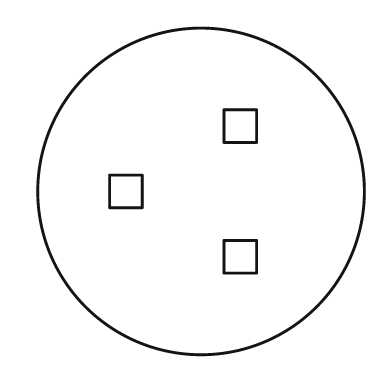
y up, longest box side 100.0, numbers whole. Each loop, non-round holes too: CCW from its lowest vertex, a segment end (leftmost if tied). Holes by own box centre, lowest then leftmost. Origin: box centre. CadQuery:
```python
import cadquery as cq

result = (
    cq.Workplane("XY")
    .moveTo(0.0, 0.0)
    .circle(50.0)
    .moveTo(7.0, -25.0)
    .lineTo(17.0, -25.0)
    .lineTo(17.0, -15.0)
    .lineTo(7.0, -15.0)
    .close()
    .moveTo(-28.0, -5.0)
    .lineTo(-18.0, -5.0)
    .lineTo(-18.0, 5.0)
    .lineTo(-28.0, 5.0)
    .close()
    .moveTo(7.0, 15.0)
    .lineTo(17.0, 15.0)
    .lineTo(17.0, 25.0)
    .lineTo(7.0, 25.0)
    .close()
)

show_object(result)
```